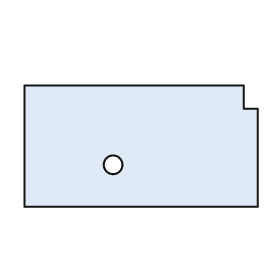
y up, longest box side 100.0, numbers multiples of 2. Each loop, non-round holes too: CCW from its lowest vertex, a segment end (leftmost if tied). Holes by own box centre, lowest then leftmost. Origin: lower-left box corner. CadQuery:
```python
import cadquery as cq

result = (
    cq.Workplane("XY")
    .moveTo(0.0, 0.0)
    .lineTo(100.0, 0.0)
    .lineTo(100.0, 42.0)
    .lineTo(94.0, 42.0)
    .lineTo(94.0, 52.0)
    .lineTo(0.0, 52.0)
    .close()
    .moveTo(38.0, 18.0)
    .circle(4.0)
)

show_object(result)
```